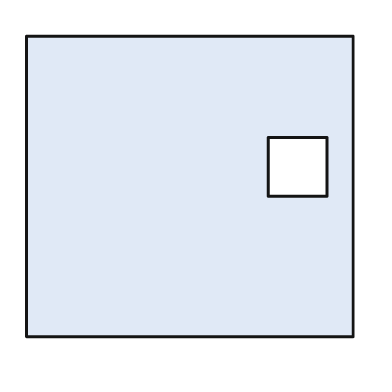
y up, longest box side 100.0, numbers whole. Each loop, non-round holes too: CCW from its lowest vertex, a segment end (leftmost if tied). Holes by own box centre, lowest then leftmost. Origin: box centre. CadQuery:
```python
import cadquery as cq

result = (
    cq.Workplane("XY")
    .moveTo(-50.0, -46.0)
    .lineTo(50.0, -46.0)
    .lineTo(50.0, 46.0)
    .lineTo(-50.0, 46.0)
    .close()
    .moveTo(24.0, -3.0)
    .lineTo(42.0, -3.0)
    .lineTo(42.0, 15.0)
    .lineTo(24.0, 15.0)
    .close()
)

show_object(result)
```